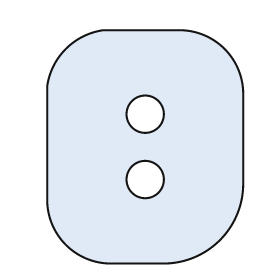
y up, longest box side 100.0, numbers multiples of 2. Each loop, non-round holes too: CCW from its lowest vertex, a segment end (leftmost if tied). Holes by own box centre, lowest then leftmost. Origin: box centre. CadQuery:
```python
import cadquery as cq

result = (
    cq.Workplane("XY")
    .moveTo(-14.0, -50.0)
    .lineTo(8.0, -50.0)
    .threePointArc((32.0, -40.0), (42.0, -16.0))
    .lineTo(42.0, 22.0)
    .threePointArc((34.0, 42.0), (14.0, 50.0))
    .lineTo(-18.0, 50.0)
    .threePointArc((-34.0, 42.0), (-42.0, 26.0))
    .lineTo(-42.0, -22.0)
    .threePointArc((-34.0, -42.0), (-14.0, -50.0))
    .close()
    .moveTo(0.0, -14.0)
    .circle(8.0)
    .moveTo(0.0, 14.0)
    .circle(8.0)
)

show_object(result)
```